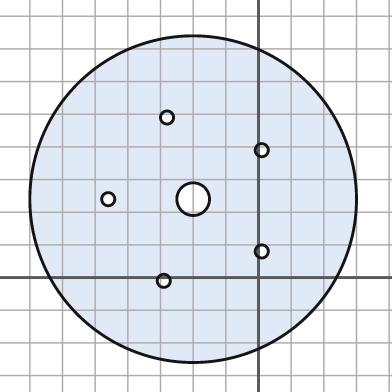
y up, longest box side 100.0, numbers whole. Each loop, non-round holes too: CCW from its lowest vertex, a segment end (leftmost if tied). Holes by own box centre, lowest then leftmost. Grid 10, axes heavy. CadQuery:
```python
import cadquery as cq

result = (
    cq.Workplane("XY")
    .moveTo(-20.0, 24.0)
    .circle(50.0)
    .moveTo(-29.0, -1.0)
    .circle(2.0)
    .moveTo(1.0, 8.0)
    .circle(2.0)
    .moveTo(-46.0, 24.0)
    .circle(2.0)
    .moveTo(-20.0, 24.0)
    .circle(5.0)
    .moveTo(1.0, 39.0)
    .circle(2.0)
    .moveTo(-28.0, 49.0)
    .circle(2.0)
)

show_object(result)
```